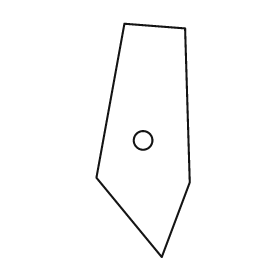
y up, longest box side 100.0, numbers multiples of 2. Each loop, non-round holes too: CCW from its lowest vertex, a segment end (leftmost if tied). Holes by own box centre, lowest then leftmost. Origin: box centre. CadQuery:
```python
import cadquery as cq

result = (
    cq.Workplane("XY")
    .moveTo(8.0, -50.0)
    .lineTo(20.0, -18.0)
    .lineTo(18.0, 48.0)
    .lineTo(-8.0, 50.0)
    .lineTo(-20.0, -16.0)
    .close()
    .moveTo(0.0, 0.0)
    .circle(4.0)
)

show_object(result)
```